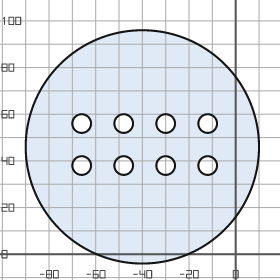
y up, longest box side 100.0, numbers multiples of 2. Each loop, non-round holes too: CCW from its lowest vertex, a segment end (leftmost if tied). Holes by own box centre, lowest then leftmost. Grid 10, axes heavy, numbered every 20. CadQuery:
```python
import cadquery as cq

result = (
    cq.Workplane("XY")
    .moveTo(-40.0, 46.0)
    .circle(50.0)
    .moveTo(-66.0, 38.0)
    .circle(4.0)
    .moveTo(-48.0, 38.0)
    .circle(4.0)
    .moveTo(-30.0, 38.0)
    .circle(4.0)
    .moveTo(-12.0, 38.0)
    .circle(4.0)
    .moveTo(-66.0, 56.0)
    .circle(4.0)
    .moveTo(-48.0, 56.0)
    .circle(4.0)
    .moveTo(-30.0, 56.0)
    .circle(4.0)
    .moveTo(-12.0, 56.0)
    .circle(4.0)
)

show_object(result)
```